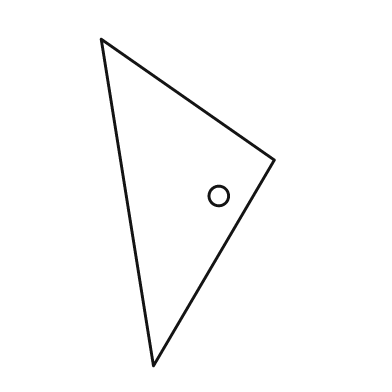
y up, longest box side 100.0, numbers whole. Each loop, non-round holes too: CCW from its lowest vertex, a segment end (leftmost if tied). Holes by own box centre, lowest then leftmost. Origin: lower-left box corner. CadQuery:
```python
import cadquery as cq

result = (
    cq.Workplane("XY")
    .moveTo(16.0, 0.0)
    .lineTo(53.0, 63.0)
    .lineTo(0.0, 100.0)
    .close()
    .moveTo(36.0, 52.0)
    .circle(3.0)
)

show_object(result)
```